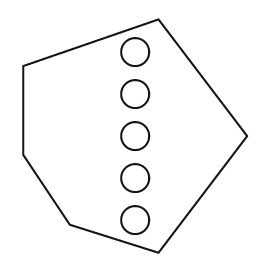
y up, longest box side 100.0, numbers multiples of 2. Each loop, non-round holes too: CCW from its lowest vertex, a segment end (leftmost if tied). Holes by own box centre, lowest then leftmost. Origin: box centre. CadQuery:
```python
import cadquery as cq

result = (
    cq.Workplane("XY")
    .moveTo(10.0, -50.0)
    .lineTo(48.0, 0.0)
    .lineTo(10.0, 50.0)
    .lineTo(-48.0, 30.0)
    .lineTo(-48.0, -8.0)
    .lineTo(-28.0, -38.0)
    .close()
    .moveTo(0.0, -36.0)
    .circle(6.0)
    .moveTo(0.0, -18.0)
    .circle(6.0)
    .moveTo(0.0, 0.0)
    .circle(6.0)
    .moveTo(0.0, 18.0)
    .circle(6.0)
    .moveTo(0.0, 36.0)
    .circle(6.0)
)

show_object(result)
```